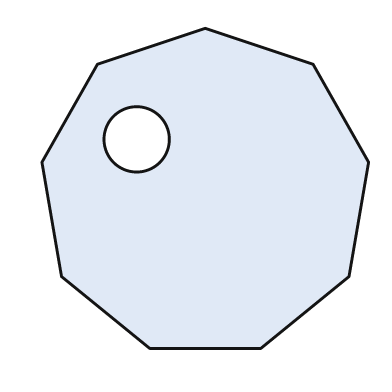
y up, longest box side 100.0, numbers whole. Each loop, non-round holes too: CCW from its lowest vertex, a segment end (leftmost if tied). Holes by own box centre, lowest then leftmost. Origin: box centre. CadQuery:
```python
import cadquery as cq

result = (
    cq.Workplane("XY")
    .moveTo(-17.0, -49.0)
    .lineTo(17.0, -49.0)
    .lineTo(44.0, -27.0)
    .lineTo(50.0, 8.0)
    .lineTo(33.0, 38.0)
    .lineTo(0.0, 49.0)
    .lineTo(-33.0, 38.0)
    .lineTo(-50.0, 8.0)
    .lineTo(-44.0, -27.0)
    .close()
    .moveTo(-21.0, 15.0)
    .circle(10.0)
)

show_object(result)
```